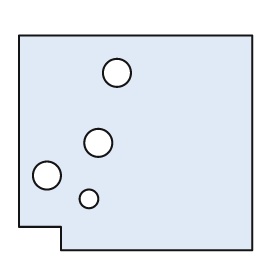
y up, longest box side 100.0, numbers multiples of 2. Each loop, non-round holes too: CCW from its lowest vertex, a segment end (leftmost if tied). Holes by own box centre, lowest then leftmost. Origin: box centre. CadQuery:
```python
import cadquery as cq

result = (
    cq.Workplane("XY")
    .moveTo(-32.0, -46.0)
    .lineTo(50.0, -46.0)
    .lineTo(50.0, 46.0)
    .lineTo(-50.0, 46.0)
    .lineTo(-50.0, -36.0)
    .lineTo(-32.0, -36.0)
    .close()
    .moveTo(-20.0, -24.0)
    .circle(4.0)
    .moveTo(-38.0, -14.0)
    .circle(6.0)
    .moveTo(-16.0, 0.0)
    .circle(6.0)
    .moveTo(-8.0, 30.0)
    .circle(6.0)
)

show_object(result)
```